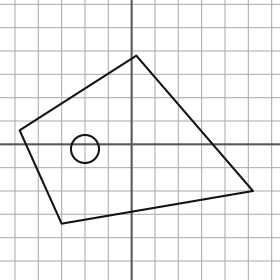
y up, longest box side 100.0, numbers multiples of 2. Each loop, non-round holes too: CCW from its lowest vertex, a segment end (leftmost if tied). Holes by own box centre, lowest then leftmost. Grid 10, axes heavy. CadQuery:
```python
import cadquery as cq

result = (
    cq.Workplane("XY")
    .moveTo(-30.0, -34.0)
    .lineTo(52.0, -20.0)
    .lineTo(2.0, 38.0)
    .lineTo(-48.0, 6.0)
    .close()
    .moveTo(-20.0, -2.0)
    .circle(6.0)
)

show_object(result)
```